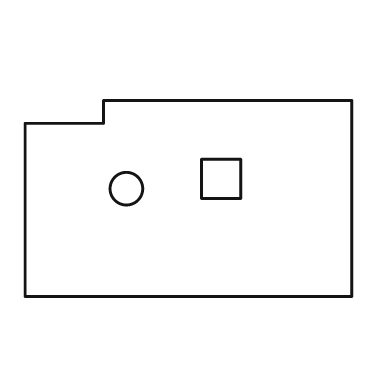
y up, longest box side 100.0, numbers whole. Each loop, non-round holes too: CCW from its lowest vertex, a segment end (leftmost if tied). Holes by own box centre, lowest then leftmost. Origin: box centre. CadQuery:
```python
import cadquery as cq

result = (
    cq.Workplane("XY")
    .moveTo(-50.0, -30.0)
    .lineTo(50.0, -30.0)
    .lineTo(50.0, 30.0)
    .lineTo(-26.0, 30.0)
    .lineTo(-26.0, 23.0)
    .lineTo(-50.0, 23.0)
    .close()
    .moveTo(-19.0, 3.0)
    .circle(5.0)
    .moveTo(4.0, 0.0)
    .lineTo(16.0, 0.0)
    .lineTo(16.0, 12.0)
    .lineTo(4.0, 12.0)
    .close()
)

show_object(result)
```